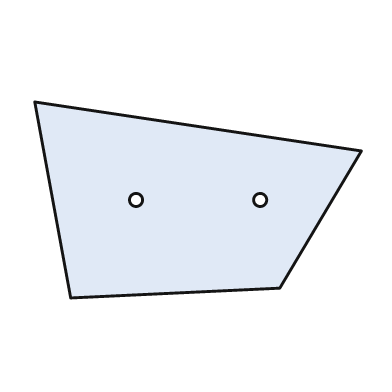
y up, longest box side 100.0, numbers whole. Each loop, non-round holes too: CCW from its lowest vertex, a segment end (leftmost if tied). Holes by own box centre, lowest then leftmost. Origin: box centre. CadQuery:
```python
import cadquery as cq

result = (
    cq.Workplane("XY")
    .moveTo(-39.0, -30.0)
    .lineTo(25.0, -27.0)
    .lineTo(50.0, 15.0)
    .lineTo(-50.0, 30.0)
    .close()
    .moveTo(-19.0, 0.0)
    .circle(2.0)
    .moveTo(19.0, 0.0)
    .circle(2.0)
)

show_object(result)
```